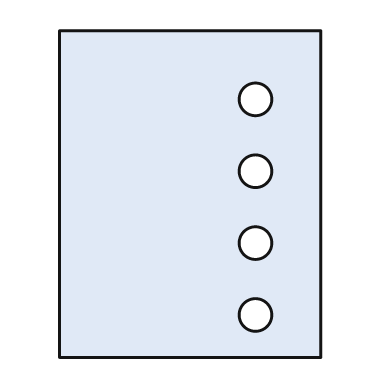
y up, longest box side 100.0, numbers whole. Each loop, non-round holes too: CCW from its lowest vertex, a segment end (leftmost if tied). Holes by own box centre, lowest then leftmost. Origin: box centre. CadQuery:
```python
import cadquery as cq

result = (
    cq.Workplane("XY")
    .moveTo(-40.0, -50.0)
    .lineTo(40.0, -50.0)
    .lineTo(40.0, 50.0)
    .lineTo(-40.0, 50.0)
    .close()
    .moveTo(20.0, -37.0)
    .circle(5.0)
    .moveTo(20.0, -15.0)
    .circle(5.0)
    .moveTo(20.0, 7.0)
    .circle(5.0)
    .moveTo(20.0, 29.0)
    .circle(5.0)
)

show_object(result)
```